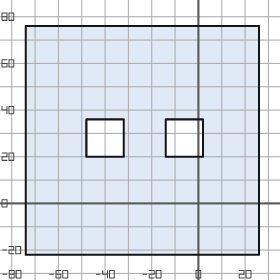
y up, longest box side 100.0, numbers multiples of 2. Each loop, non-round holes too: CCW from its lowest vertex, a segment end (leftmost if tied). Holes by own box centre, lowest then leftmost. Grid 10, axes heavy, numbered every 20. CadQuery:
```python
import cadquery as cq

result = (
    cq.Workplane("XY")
    .moveTo(-74.0, -22.0)
    .lineTo(26.0, -22.0)
    .lineTo(26.0, 76.0)
    .lineTo(-74.0, 76.0)
    .close()
    .moveTo(-48.0, 20.0)
    .lineTo(-32.0, 20.0)
    .lineTo(-32.0, 36.0)
    .lineTo(-48.0, 36.0)
    .close()
    .moveTo(-14.0, 20.0)
    .lineTo(2.0, 20.0)
    .lineTo(2.0, 36.0)
    .lineTo(-14.0, 36.0)
    .close()
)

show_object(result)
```